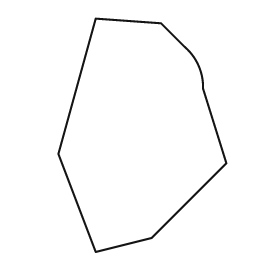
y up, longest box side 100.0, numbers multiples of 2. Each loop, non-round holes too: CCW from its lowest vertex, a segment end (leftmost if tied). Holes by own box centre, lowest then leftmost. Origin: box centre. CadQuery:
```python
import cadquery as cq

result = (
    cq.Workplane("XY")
    .moveTo(-20.0, -50.0)
    .lineTo(4.0, -44.0)
    .lineTo(36.0, -12.0)
    .lineTo(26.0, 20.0)
    .threePointArc((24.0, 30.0), (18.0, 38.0))
    .lineTo(8.0, 48.0)
    .lineTo(-20.0, 50.0)
    .lineTo(-36.0, -8.0)
    .close()
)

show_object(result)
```